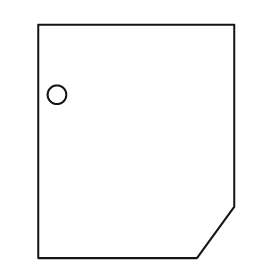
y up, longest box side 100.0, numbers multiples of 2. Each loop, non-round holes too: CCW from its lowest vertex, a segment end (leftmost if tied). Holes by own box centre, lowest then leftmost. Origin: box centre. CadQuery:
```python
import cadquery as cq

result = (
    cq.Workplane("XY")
    .moveTo(-42.0, -50.0)
    .lineTo(26.0, -50.0)
    .lineTo(42.0, -28.0)
    .lineTo(42.0, 50.0)
    .lineTo(-42.0, 50.0)
    .close()
    .moveTo(-34.0, 20.0)
    .circle(4.0)
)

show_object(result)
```